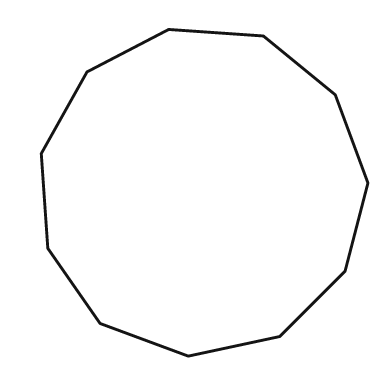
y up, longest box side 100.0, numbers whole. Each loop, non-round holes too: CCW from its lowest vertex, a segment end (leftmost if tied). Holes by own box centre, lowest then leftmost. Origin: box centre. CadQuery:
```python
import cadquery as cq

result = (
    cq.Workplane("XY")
    .moveTo(-5.0, -50.0)
    .lineTo(23.0, -44.0)
    .lineTo(43.0, -24.0)
    .lineTo(50.0, 3.0)
    .lineTo(40.0, 30.0)
    .lineTo(18.0, 48.0)
    .lineTo(-11.0, 50.0)
    .lineTo(-36.0, 37.0)
    .lineTo(-50.0, 12.0)
    .lineTo(-48.0, -17.0)
    .lineTo(-32.0, -40.0)
    .close()
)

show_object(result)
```